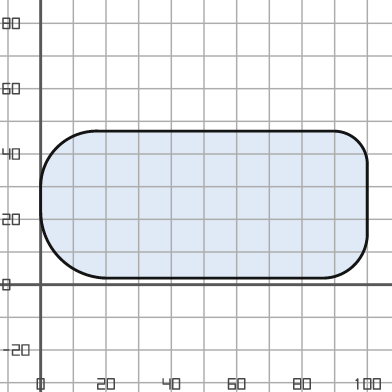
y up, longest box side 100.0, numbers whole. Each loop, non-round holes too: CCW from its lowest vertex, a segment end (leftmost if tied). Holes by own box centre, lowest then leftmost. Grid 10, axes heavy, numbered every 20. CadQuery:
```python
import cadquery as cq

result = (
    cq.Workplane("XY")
    .moveTo(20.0, 2.0)
    .lineTo(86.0, 2.0)
    .threePointArc((96.0, 6.0), (100.0, 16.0))
    .lineTo(100.0, 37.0)
    .threePointArc((97.0, 44.0), (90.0, 47.0))
    .lineTo(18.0, 47.0)
    .threePointArc((5.0, 42.0), (0.0, 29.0))
    .lineTo(0.0, 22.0)
    .threePointArc((6.0, 8.0), (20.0, 2.0))
    .close()
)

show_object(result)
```